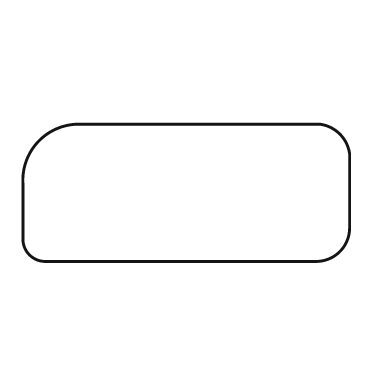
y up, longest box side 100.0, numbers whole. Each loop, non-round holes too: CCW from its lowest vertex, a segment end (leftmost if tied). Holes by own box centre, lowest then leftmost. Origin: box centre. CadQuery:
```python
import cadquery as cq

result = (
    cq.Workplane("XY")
    .moveTo(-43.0, -21.0)
    .lineTo(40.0, -21.0)
    .threePointArc((47.0, -18.0), (50.0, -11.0))
    .lineTo(50.0, 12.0)
    .threePointArc((47.0, 18.0), (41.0, 21.0))
    .lineTo(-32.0, 21.0)
    .threePointArc((-45.0, 16.0), (-50.0, 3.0))
    .lineTo(-50.0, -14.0)
    .threePointArc((-48.0, -19.0), (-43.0, -21.0))
    .close()
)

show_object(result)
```